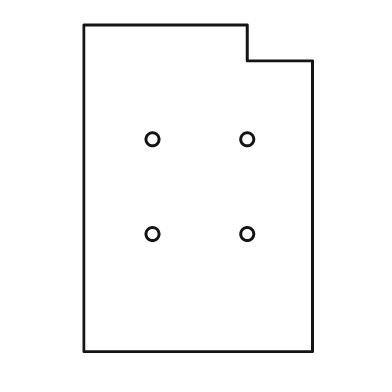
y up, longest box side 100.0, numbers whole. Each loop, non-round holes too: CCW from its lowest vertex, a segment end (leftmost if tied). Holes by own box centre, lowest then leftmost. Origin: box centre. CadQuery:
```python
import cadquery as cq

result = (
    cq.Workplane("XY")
    .moveTo(-35.0, -50.0)
    .lineTo(35.0, -50.0)
    .lineTo(35.0, 39.0)
    .lineTo(15.0, 39.0)
    .lineTo(15.0, 50.0)
    .lineTo(-35.0, 50.0)
    .close()
    .moveTo(-14.0, -14.0)
    .circle(2.0)
    .moveTo(15.0, -14.0)
    .circle(2.0)
    .moveTo(-14.0, 15.0)
    .circle(2.0)
    .moveTo(15.0, 15.0)
    .circle(2.0)
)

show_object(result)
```